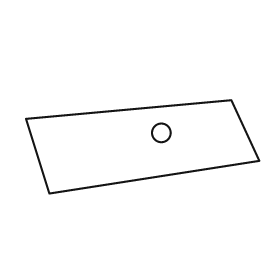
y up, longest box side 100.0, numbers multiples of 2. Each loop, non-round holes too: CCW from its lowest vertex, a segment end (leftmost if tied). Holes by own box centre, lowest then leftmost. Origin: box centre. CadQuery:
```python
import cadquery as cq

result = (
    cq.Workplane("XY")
    .moveTo(-40.0, -20.0)
    .lineTo(50.0, -6.0)
    .lineTo(38.0, 20.0)
    .lineTo(-50.0, 12.0)
    .close()
    .moveTo(8.0, 6.0)
    .circle(4.0)
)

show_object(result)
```